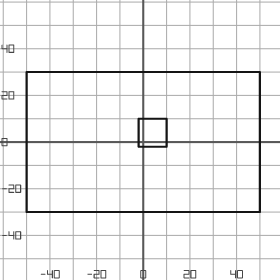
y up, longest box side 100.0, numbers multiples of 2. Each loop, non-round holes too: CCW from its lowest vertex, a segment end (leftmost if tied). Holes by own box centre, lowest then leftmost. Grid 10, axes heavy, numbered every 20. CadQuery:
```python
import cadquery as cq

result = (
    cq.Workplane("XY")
    .moveTo(-50.0, -30.0)
    .lineTo(50.0, -30.0)
    .lineTo(50.0, 30.0)
    .lineTo(-50.0, 30.0)
    .close()
    .moveTo(-2.0, -2.0)
    .lineTo(10.0, -2.0)
    .lineTo(10.0, 10.0)
    .lineTo(-2.0, 10.0)
    .close()
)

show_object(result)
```